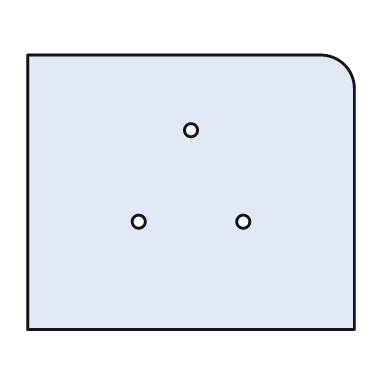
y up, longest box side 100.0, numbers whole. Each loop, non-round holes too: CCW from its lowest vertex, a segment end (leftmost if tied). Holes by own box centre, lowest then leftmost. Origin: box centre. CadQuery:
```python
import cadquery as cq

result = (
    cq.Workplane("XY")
    .moveTo(-50.0, -42.0)
    .lineTo(50.0, -42.0)
    .lineTo(50.0, 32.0)
    .threePointArc((47.0, 39.0), (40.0, 42.0))
    .lineTo(-50.0, 42.0)
    .close()
    .moveTo(-16.0, -9.0)
    .circle(2.0)
    .moveTo(16.0, -9.0)
    .circle(2.0)
    .moveTo(0.0, 19.0)
    .circle(2.0)
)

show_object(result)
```